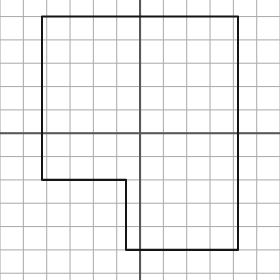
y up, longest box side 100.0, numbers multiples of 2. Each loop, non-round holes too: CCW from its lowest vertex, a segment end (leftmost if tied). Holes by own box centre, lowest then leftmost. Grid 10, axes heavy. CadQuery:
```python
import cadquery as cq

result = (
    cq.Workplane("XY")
    .moveTo(-6.0, -50.0)
    .lineTo(42.0, -50.0)
    .lineTo(42.0, 50.0)
    .lineTo(-42.0, 50.0)
    .lineTo(-42.0, -20.0)
    .lineTo(-6.0, -20.0)
    .close()
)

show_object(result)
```